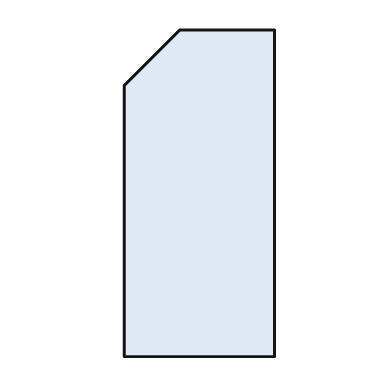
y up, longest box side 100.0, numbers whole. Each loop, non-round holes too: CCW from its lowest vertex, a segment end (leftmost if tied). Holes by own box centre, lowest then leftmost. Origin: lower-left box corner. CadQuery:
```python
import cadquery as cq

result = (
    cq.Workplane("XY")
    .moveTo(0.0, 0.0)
    .lineTo(46.0, 0.0)
    .lineTo(46.0, 100.0)
    .lineTo(17.0, 100.0)
    .lineTo(0.0, 83.0)
    .close()
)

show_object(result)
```